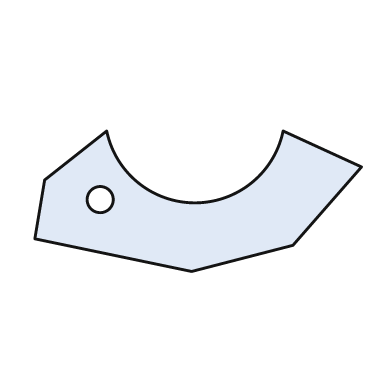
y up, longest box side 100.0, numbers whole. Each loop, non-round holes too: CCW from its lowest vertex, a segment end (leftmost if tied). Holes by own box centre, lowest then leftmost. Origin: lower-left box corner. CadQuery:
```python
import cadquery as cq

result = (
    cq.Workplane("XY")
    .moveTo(48.0, 0.0)
    .lineTo(79.0, 8.0)
    .lineTo(100.0, 32.0)
    .lineTo(76.0, 43.0)
    .threePointArc((49.0, 21.0), (22.0, 43.0))
    .lineTo(3.0, 28.0)
    .lineTo(0.0, 10.0)
    .close()
    .moveTo(20.0, 22.0)
    .circle(4.0)
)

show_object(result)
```